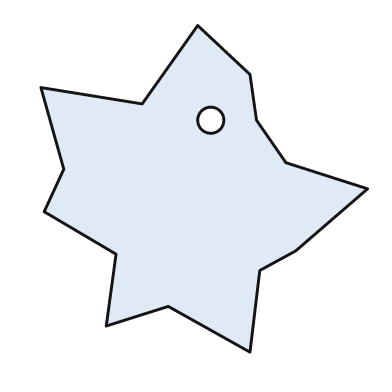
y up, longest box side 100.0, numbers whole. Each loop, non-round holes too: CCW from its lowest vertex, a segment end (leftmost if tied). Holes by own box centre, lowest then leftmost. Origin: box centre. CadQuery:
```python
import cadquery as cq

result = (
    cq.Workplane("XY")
    .moveTo(14.0, -50.0)
    .lineTo(17.0, -25.0)
    .lineTo(28.0, -19.0)
    .lineTo(50.0, 0.0)
    .lineTo(25.0, 8.0)
    .lineTo(16.0, 21.0)
    .lineTo(14.0, 35.0)
    .lineTo(-2.0, 50.0)
    .lineTo(-19.0, 26.0)
    .lineTo(-50.0, 31.0)
    .lineTo(-43.0, 6.0)
    .lineTo(-49.0, -7.0)
    .lineTo(-27.0, -20.0)
    .lineTo(-30.0, -42.0)
    .lineTo(-11.0, -36.0)
    .close()
    .moveTo(2.0, 21.0)
    .circle(4.0)
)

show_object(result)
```